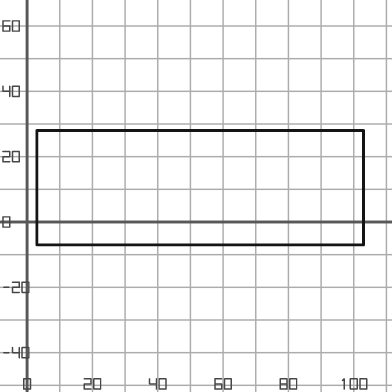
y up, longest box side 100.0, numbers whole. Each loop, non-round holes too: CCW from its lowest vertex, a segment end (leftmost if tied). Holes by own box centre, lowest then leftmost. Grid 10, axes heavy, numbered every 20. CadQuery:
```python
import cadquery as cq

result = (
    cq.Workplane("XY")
    .moveTo(3.0, -7.0)
    .lineTo(103.0, -7.0)
    .lineTo(103.0, 28.0)
    .lineTo(3.0, 28.0)
    .close()
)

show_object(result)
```